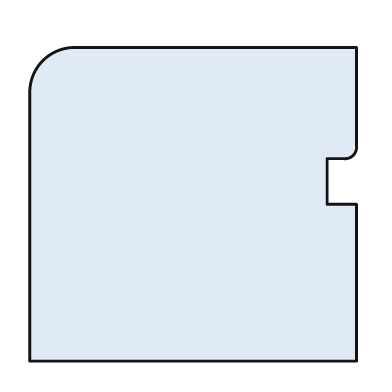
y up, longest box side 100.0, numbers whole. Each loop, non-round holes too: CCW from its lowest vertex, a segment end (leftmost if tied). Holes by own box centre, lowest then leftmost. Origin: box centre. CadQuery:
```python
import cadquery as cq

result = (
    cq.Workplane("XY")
    .moveTo(-50.0, -48.0)
    .lineTo(50.0, -48.0)
    .lineTo(50.0, 0.0)
    .lineTo(41.0, 0.0)
    .lineTo(41.0, 14.0)
    .lineTo(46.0, 14.0)
    .threePointArc((49.0, 15.0), (50.0, 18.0))
    .lineTo(50.0, 48.0)
    .lineTo(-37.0, 48.0)
    .threePointArc((-46.0, 44.0), (-50.0, 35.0))
    .close()
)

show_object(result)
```